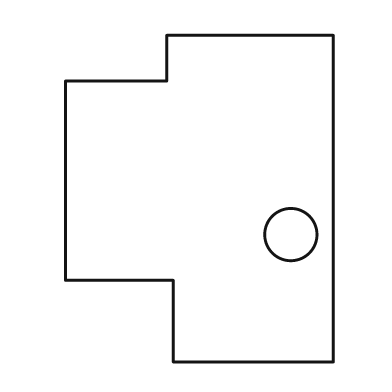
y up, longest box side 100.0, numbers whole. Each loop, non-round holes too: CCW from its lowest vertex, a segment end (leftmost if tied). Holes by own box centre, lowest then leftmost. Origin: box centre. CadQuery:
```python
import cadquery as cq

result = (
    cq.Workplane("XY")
    .moveTo(-8.0, -50.0)
    .lineTo(41.0, -50.0)
    .lineTo(41.0, 50.0)
    .lineTo(-10.0, 50.0)
    .lineTo(-10.0, 36.0)
    .lineTo(-41.0, 36.0)
    .lineTo(-41.0, -25.0)
    .lineTo(-8.0, -25.0)
    .close()
    .moveTo(28.0, -11.0)
    .circle(8.0)
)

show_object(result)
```